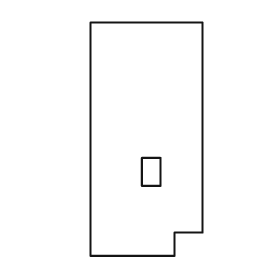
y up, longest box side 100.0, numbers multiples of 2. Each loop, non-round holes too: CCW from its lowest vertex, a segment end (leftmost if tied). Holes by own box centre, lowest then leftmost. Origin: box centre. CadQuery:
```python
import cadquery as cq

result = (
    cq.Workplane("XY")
    .moveTo(-24.0, -50.0)
    .lineTo(12.0, -50.0)
    .lineTo(12.0, -40.0)
    .lineTo(24.0, -40.0)
    .lineTo(24.0, 50.0)
    .lineTo(-24.0, 50.0)
    .close()
    .moveTo(-2.0, -20.0)
    .lineTo(6.0, -20.0)
    .lineTo(6.0, -8.0)
    .lineTo(-2.0, -8.0)
    .close()
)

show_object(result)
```